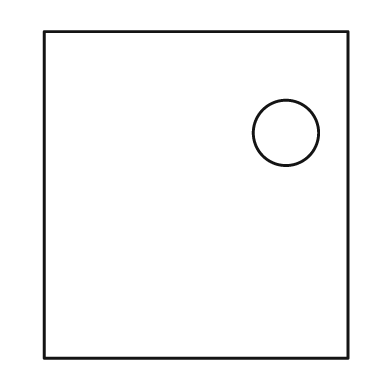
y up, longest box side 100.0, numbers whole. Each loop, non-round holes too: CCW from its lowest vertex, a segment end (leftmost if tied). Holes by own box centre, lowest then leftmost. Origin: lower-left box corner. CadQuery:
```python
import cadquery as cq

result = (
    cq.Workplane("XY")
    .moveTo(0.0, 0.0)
    .lineTo(93.0, 0.0)
    .lineTo(93.0, 100.0)
    .lineTo(0.0, 100.0)
    .close()
    .moveTo(74.0, 69.0)
    .circle(10.0)
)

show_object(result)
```